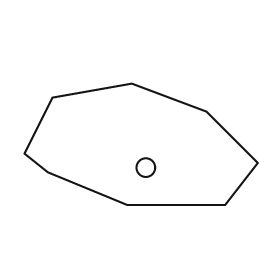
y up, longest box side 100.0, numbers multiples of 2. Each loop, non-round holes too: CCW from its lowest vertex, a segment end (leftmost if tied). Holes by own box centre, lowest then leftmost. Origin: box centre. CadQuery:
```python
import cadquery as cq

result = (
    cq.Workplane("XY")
    .moveTo(-6.0, -26.0)
    .lineTo(36.0, -26.0)
    .lineTo(50.0, -8.0)
    .lineTo(28.0, 14.0)
    .lineTo(-4.0, 26.0)
    .lineTo(-38.0, 20.0)
    .lineTo(-50.0, -4.0)
    .lineTo(-40.0, -12.0)
    .close()
    .moveTo(2.0, -10.0)
    .circle(4.0)
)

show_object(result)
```